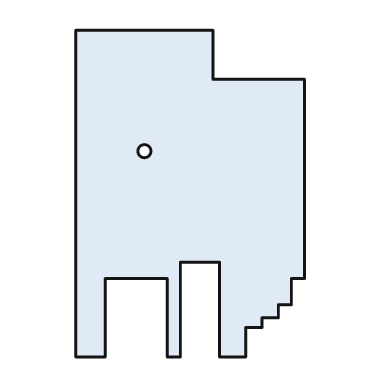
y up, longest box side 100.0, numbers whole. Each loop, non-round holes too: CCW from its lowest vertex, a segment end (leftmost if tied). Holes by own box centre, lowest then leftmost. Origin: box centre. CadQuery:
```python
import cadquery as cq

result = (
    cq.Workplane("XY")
    .moveTo(-35.0, -50.0)
    .lineTo(-26.0, -50.0)
    .lineTo(-26.0, -26.0)
    .lineTo(-7.0, -26.0)
    .lineTo(-7.0, -50.0)
    .lineTo(-3.0, -50.0)
    .lineTo(-3.0, -21.0)
    .lineTo(9.0, -21.0)
    .lineTo(9.0, -50.0)
    .lineTo(17.0, -50.0)
    .lineTo(17.0, -41.0)
    .lineTo(22.0, -41.0)
    .lineTo(22.0, -38.0)
    .lineTo(27.0, -38.0)
    .lineTo(27.0, -34.0)
    .lineTo(31.0, -34.0)
    .lineTo(31.0, -26.0)
    .lineTo(35.0, -26.0)
    .lineTo(35.0, 35.0)
    .lineTo(7.0, 35.0)
    .lineTo(7.0, 50.0)
    .lineTo(-35.0, 50.0)
    .close()
    .moveTo(-14.0, 13.0)
    .circle(2.0)
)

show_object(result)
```